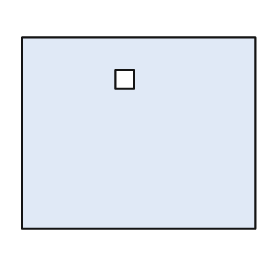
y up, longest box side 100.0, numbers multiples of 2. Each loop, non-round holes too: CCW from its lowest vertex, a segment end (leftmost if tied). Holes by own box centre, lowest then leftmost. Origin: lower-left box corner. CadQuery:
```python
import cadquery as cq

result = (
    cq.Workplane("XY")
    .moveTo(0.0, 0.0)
    .lineTo(100.0, 0.0)
    .lineTo(100.0, 82.0)
    .lineTo(0.0, 82.0)
    .close()
    .moveTo(40.0, 60.0)
    .lineTo(48.0, 60.0)
    .lineTo(48.0, 68.0)
    .lineTo(40.0, 68.0)
    .close()
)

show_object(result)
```